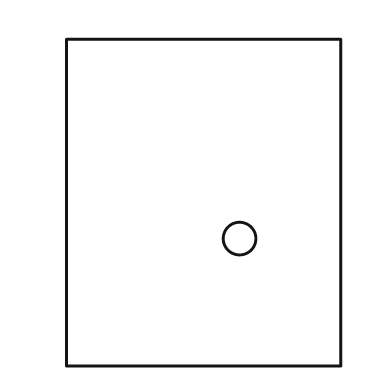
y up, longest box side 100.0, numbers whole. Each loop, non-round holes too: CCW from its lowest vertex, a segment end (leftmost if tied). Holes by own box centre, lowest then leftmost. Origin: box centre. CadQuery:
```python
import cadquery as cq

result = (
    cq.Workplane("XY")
    .moveTo(-42.0, -50.0)
    .lineTo(42.0, -50.0)
    .lineTo(42.0, 50.0)
    .lineTo(-42.0, 50.0)
    .close()
    .moveTo(11.0, -11.0)
    .circle(5.0)
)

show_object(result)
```